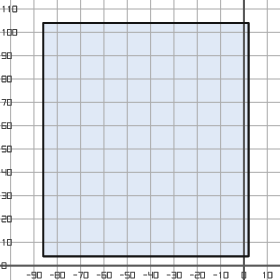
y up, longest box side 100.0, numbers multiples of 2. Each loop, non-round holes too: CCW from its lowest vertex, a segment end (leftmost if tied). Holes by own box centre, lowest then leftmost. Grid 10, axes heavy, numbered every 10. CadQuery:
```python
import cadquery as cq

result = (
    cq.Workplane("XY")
    .moveTo(-86.0, 4.0)
    .lineTo(2.0, 4.0)
    .lineTo(2.0, 104.0)
    .lineTo(-86.0, 104.0)
    .close()
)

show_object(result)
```